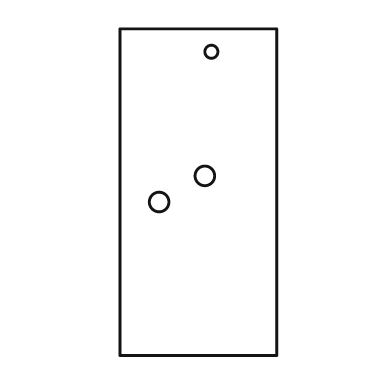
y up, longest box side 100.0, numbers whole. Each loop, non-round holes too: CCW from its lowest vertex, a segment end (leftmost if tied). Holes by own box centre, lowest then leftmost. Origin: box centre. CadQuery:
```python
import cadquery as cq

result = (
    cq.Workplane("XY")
    .moveTo(-24.0, -50.0)
    .lineTo(24.0, -50.0)
    .lineTo(24.0, 50.0)
    .lineTo(-24.0, 50.0)
    .close()
    .moveTo(-12.0, -3.0)
    .circle(3.0)
    .moveTo(2.0, 5.0)
    .circle(3.0)
    .moveTo(4.0, 43.0)
    .circle(2.0)
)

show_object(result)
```